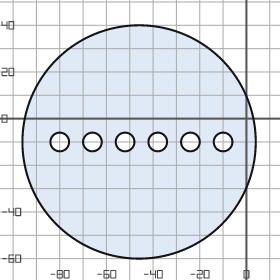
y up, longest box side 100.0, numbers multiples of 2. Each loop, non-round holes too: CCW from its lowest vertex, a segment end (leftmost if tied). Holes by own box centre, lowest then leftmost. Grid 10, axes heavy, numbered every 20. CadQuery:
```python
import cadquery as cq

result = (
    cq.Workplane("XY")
    .moveTo(-46.0, -10.0)
    .circle(50.0)
    .moveTo(-80.0, -10.0)
    .circle(4.0)
    .moveTo(-66.0, -10.0)
    .circle(4.0)
    .moveTo(-52.0, -10.0)
    .circle(4.0)
    .moveTo(-38.0, -10.0)
    .circle(4.0)
    .moveTo(-24.0, -10.0)
    .circle(4.0)
    .moveTo(-10.0, -10.0)
    .circle(4.0)
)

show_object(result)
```